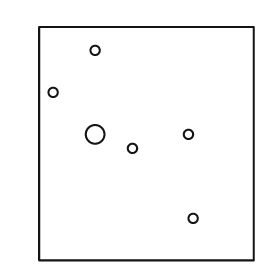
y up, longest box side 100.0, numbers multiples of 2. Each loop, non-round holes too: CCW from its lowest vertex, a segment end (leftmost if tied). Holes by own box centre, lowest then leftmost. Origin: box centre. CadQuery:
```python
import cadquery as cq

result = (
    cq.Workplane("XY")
    .moveTo(-46.0, -50.0)
    .lineTo(46.0, -50.0)
    .lineTo(46.0, 50.0)
    .lineTo(-46.0, 50.0)
    .close()
    .moveTo(20.0, -32.0)
    .circle(2.0)
    .moveTo(-6.0, -2.0)
    .circle(2.0)
    .moveTo(-22.0, 4.0)
    .circle(4.0)
    .moveTo(18.0, 4.0)
    .circle(2.0)
    .moveTo(-40.0, 22.0)
    .circle(2.0)
    .moveTo(-22.0, 40.0)
    .circle(2.0)
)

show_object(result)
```